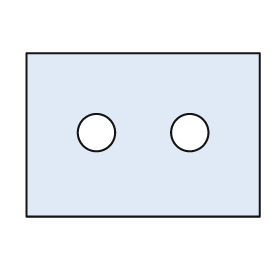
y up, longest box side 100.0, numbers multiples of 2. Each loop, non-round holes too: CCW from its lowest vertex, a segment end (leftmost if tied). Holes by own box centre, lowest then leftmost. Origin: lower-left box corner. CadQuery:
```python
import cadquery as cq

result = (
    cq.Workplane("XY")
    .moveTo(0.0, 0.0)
    .lineTo(100.0, 0.0)
    .lineTo(100.0, 70.0)
    .lineTo(0.0, 70.0)
    .close()
    .moveTo(30.0, 36.0)
    .circle(8.0)
    .moveTo(70.0, 36.0)
    .circle(8.0)
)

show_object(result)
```